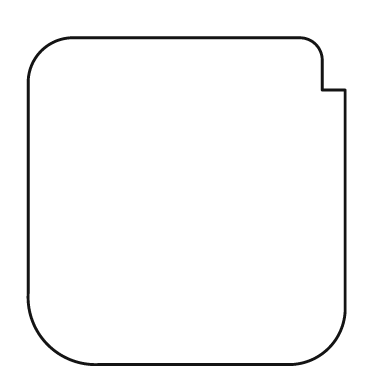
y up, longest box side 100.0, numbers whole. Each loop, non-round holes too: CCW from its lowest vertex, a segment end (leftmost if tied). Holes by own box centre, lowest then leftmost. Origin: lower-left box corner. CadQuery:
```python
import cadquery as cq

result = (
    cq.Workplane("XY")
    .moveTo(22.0, 0.0)
    .lineTo(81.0, 0.0)
    .threePointArc((92.0, 5.0), (97.0, 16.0))
    .lineTo(97.0, 84.0)
    .lineTo(90.0, 84.0)
    .lineTo(90.0, 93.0)
    .threePointArc((88.0, 98.0), (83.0, 100.0))
    .lineTo(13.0, 100.0)
    .threePointArc((4.0, 96.0), (0.0, 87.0))
    .lineTo(0.0, 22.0)
    .threePointArc((6.0, 6.0), (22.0, 0.0))
    .close()
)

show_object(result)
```